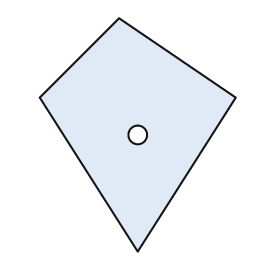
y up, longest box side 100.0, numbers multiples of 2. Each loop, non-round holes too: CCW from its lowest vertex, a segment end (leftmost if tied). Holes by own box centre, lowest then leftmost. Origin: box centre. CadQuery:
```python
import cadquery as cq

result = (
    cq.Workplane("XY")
    .moveTo(0.0, -50.0)
    .lineTo(42.0, 16.0)
    .lineTo(-8.0, 50.0)
    .lineTo(-42.0, 16.0)
    .close()
    .moveTo(0.0, 0.0)
    .circle(4.0)
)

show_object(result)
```